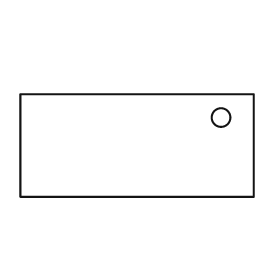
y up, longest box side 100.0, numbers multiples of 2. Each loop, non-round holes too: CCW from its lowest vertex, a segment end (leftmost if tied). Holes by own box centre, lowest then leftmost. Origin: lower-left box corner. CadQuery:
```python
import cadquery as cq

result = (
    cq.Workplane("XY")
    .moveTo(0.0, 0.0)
    .lineTo(100.0, 0.0)
    .lineTo(100.0, 44.0)
    .lineTo(0.0, 44.0)
    .close()
    .moveTo(86.0, 34.0)
    .circle(4.0)
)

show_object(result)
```